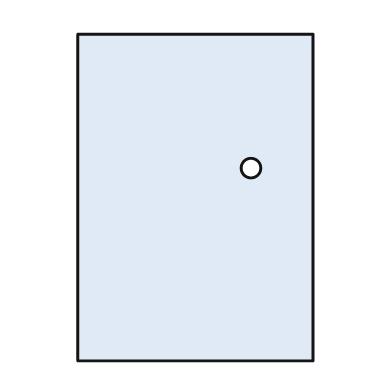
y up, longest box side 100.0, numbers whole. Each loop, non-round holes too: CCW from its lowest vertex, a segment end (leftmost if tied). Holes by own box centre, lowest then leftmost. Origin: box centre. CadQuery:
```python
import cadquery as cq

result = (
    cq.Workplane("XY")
    .moveTo(-36.0, -50.0)
    .lineTo(36.0, -50.0)
    .lineTo(36.0, 50.0)
    .lineTo(-36.0, 50.0)
    .close()
    .moveTo(17.0, 9.0)
    .circle(3.0)
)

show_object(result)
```